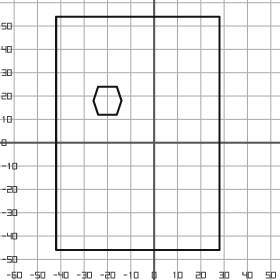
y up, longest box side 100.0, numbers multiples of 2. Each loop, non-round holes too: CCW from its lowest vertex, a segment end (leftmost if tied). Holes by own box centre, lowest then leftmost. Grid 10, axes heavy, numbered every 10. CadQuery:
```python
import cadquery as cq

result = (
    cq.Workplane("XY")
    .moveTo(-42.0, -46.0)
    .lineTo(28.0, -46.0)
    .lineTo(28.0, 54.0)
    .lineTo(-42.0, 54.0)
    .close()
    .moveTo(-24.0, 12.0)
    .lineTo(-16.0, 12.0)
    .lineTo(-14.0, 18.0)
    .lineTo(-16.0, 24.0)
    .lineTo(-24.0, 24.0)
    .lineTo(-26.0, 18.0)
    .close()
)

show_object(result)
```